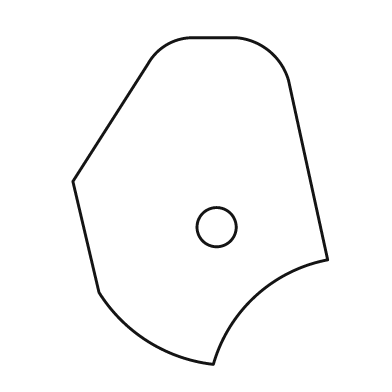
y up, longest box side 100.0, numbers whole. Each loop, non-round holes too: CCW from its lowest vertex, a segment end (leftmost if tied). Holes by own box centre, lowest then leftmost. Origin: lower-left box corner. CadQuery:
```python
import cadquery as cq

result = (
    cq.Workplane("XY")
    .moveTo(43.0, 0.0)
    .threePointArc((56.0, 21.0), (78.0, 32.0))
    .lineTo(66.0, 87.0)
    .threePointArc((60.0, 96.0), (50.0, 100.0))
    .lineTo(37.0, 100.0)
    .threePointArc((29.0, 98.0), (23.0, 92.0))
    .lineTo(0.0, 56.0)
    .lineTo(8.0, 22.0)
    .threePointArc((23.0, 7.0), (43.0, 0.0))
    .close()
    .moveTo(44.0, 42.0)
    .circle(6.0)
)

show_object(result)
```